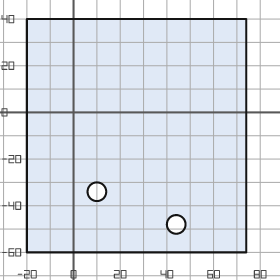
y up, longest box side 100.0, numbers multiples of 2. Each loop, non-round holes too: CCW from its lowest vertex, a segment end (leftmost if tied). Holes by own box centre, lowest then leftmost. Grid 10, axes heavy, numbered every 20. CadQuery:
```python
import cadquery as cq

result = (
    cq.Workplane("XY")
    .moveTo(-20.0, -60.0)
    .lineTo(74.0, -60.0)
    .lineTo(74.0, 40.0)
    .lineTo(-20.0, 40.0)
    .close()
    .moveTo(44.0, -48.0)
    .circle(4.0)
    .moveTo(10.0, -34.0)
    .circle(4.0)
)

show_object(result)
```